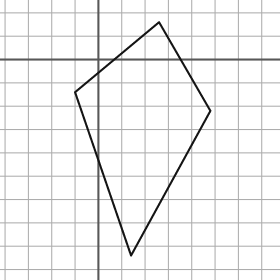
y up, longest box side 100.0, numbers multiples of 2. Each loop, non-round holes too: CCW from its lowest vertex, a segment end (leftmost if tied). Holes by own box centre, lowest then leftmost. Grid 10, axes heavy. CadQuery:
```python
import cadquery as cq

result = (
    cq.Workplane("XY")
    .moveTo(14.0, -84.0)
    .lineTo(48.0, -22.0)
    .lineTo(26.0, 16.0)
    .lineTo(-10.0, -14.0)
    .close()
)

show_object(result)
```